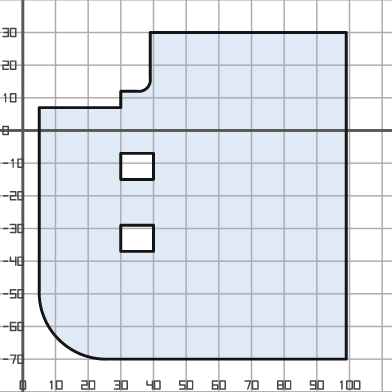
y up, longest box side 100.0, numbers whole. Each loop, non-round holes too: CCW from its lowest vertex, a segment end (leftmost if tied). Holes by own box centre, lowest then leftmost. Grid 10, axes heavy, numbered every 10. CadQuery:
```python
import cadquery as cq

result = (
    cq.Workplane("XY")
    .moveTo(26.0, -70.0)
    .lineTo(99.0, -70.0)
    .lineTo(99.0, 30.0)
    .lineTo(39.0, 30.0)
    .lineTo(39.0, 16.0)
    .threePointArc((38.0, 13.0), (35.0, 12.0))
    .lineTo(30.0, 12.0)
    .lineTo(30.0, 7.0)
    .lineTo(5.0, 7.0)
    .lineTo(5.0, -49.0)
    .threePointArc((11.0, -64.0), (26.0, -70.0))
    .close()
    .moveTo(30.0, -37.0)
    .lineTo(40.0, -37.0)
    .lineTo(40.0, -29.0)
    .lineTo(30.0, -29.0)
    .close()
    .moveTo(30.0, -15.0)
    .lineTo(40.0, -15.0)
    .lineTo(40.0, -7.0)
    .lineTo(30.0, -7.0)
    .close()
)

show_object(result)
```